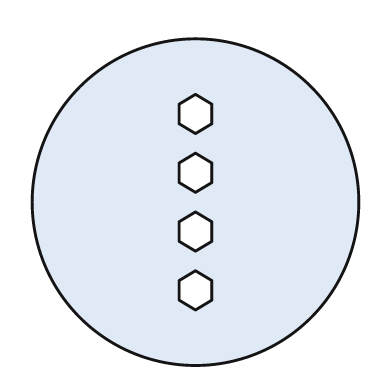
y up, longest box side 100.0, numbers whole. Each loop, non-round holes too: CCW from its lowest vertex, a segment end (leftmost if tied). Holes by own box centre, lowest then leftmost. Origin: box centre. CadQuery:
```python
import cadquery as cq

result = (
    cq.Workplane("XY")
    .moveTo(0.0, 0.0)
    .circle(50.0)
    .moveTo(0.0, -33.0)
    .lineTo(5.0, -30.0)
    .lineTo(5.0, -24.0)
    .lineTo(0.0, -21.0)
    .lineTo(-5.0, -24.0)
    .lineTo(-5.0, -30.0)
    .close()
    .moveTo(0.0, -15.0)
    .lineTo(5.0, -12.0)
    .lineTo(5.0, -6.0)
    .lineTo(0.0, -3.0)
    .lineTo(-5.0, -6.0)
    .lineTo(-5.0, -12.0)
    .close()
    .moveTo(0.0, 3.0)
    .lineTo(5.0, 6.0)
    .lineTo(5.0, 12.0)
    .lineTo(0.0, 15.0)
    .lineTo(-5.0, 12.0)
    .lineTo(-5.0, 6.0)
    .close()
    .moveTo(0.0, 21.0)
    .lineTo(5.0, 24.0)
    .lineTo(5.0, 30.0)
    .lineTo(0.0, 33.0)
    .lineTo(-5.0, 30.0)
    .lineTo(-5.0, 24.0)
    .close()
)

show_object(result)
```